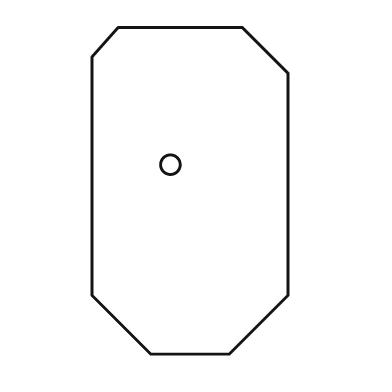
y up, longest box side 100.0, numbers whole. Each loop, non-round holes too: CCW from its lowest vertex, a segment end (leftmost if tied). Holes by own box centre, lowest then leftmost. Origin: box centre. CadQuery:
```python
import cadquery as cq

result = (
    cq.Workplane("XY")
    .moveTo(-12.0, -50.0)
    .lineTo(12.0, -50.0)
    .lineTo(30.0, -32.0)
    .lineTo(30.0, 36.0)
    .lineTo(16.0, 50.0)
    .lineTo(-22.0, 50.0)
    .lineTo(-30.0, 41.0)
    .lineTo(-30.0, -32.0)
    .close()
    .moveTo(-6.0, 8.0)
    .circle(3.0)
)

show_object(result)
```